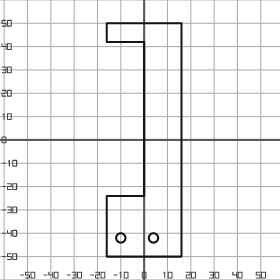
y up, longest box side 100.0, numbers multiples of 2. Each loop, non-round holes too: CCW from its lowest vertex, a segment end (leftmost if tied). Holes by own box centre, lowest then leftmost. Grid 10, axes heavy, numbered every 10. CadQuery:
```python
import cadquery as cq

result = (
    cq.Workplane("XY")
    .moveTo(-16.0, -50.0)
    .lineTo(16.0, -50.0)
    .lineTo(16.0, 50.0)
    .lineTo(-16.0, 50.0)
    .lineTo(-16.0, 42.0)
    .lineTo(0.0, 42.0)
    .lineTo(0.0, -24.0)
    .lineTo(-16.0, -24.0)
    .close()
    .moveTo(-10.0, -42.0)
    .circle(2.0)
    .moveTo(4.0, -42.0)
    .circle(2.0)
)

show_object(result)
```